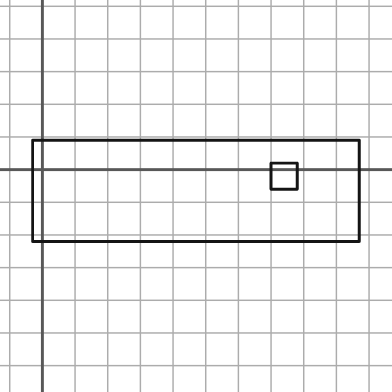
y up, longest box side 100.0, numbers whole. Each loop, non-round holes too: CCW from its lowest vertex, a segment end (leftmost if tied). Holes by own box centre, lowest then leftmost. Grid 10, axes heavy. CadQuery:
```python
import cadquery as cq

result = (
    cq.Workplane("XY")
    .moveTo(-3.0, -22.0)
    .lineTo(97.0, -22.0)
    .lineTo(97.0, 9.0)
    .lineTo(-3.0, 9.0)
    .close()
    .moveTo(70.0, -6.0)
    .lineTo(78.0, -6.0)
    .lineTo(78.0, 2.0)
    .lineTo(70.0, 2.0)
    .close()
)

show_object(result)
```